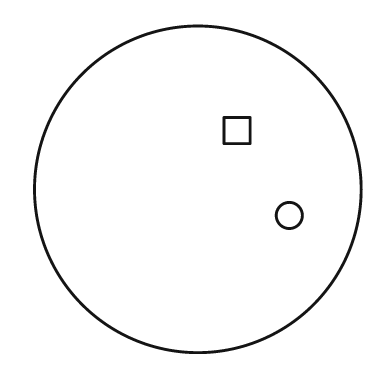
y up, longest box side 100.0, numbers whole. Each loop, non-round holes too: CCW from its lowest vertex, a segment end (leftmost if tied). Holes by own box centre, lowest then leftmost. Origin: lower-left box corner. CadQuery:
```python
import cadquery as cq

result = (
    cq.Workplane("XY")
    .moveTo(50.0, 50.0)
    .circle(50.0)
    .moveTo(78.0, 42.0)
    .circle(4.0)
    .moveTo(58.0, 64.0)
    .lineTo(66.0, 64.0)
    .lineTo(66.0, 72.0)
    .lineTo(58.0, 72.0)
    .close()
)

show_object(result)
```